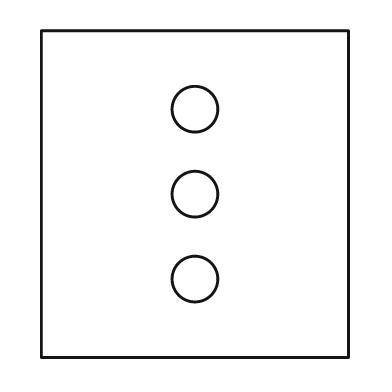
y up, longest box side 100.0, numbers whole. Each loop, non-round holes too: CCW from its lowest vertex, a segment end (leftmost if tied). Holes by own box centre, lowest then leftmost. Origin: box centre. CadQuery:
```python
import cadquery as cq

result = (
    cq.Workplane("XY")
    .moveTo(-47.0, -50.0)
    .lineTo(47.0, -50.0)
    .lineTo(47.0, 50.0)
    .lineTo(-47.0, 50.0)
    .close()
    .moveTo(0.0, -26.0)
    .circle(7.0)
    .moveTo(0.0, 0.0)
    .circle(7.0)
    .moveTo(0.0, 26.0)
    .circle(7.0)
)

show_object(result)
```